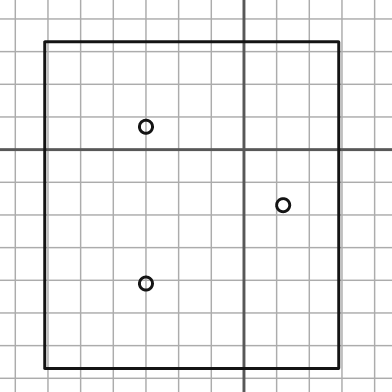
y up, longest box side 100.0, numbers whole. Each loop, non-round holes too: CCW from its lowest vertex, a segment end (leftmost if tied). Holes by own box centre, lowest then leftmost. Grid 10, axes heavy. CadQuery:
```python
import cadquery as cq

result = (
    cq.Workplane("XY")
    .moveTo(-61.0, -67.0)
    .lineTo(29.0, -67.0)
    .lineTo(29.0, 33.0)
    .lineTo(-61.0, 33.0)
    .close()
    .moveTo(-30.0, -41.0)
    .circle(2.0)
    .moveTo(12.0, -17.0)
    .circle(2.0)
    .moveTo(-30.0, 7.0)
    .circle(2.0)
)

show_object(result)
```